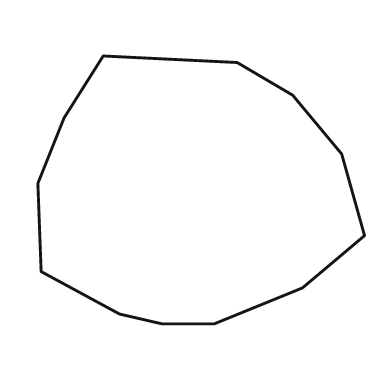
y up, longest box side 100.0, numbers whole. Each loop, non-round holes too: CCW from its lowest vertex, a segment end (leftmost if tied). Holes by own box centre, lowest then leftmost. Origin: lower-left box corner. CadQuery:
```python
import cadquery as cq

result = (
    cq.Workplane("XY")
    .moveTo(38.0, 0.0)
    .lineTo(54.0, 0.0)
    .lineTo(81.0, 11.0)
    .lineTo(100.0, 27.0)
    .lineTo(93.0, 52.0)
    .lineTo(78.0, 70.0)
    .lineTo(61.0, 80.0)
    .lineTo(20.0, 82.0)
    .lineTo(8.0, 63.0)
    .lineTo(0.0, 43.0)
    .lineTo(1.0, 16.0)
    .lineTo(25.0, 3.0)
    .close()
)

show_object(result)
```